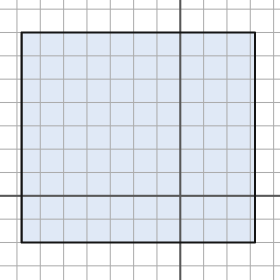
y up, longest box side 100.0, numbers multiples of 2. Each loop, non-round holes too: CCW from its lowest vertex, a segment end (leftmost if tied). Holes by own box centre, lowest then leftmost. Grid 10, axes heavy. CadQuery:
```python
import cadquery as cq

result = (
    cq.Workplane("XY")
    .moveTo(-68.0, -20.0)
    .lineTo(32.0, -20.0)
    .lineTo(32.0, 70.0)
    .lineTo(-68.0, 70.0)
    .close()
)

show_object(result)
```